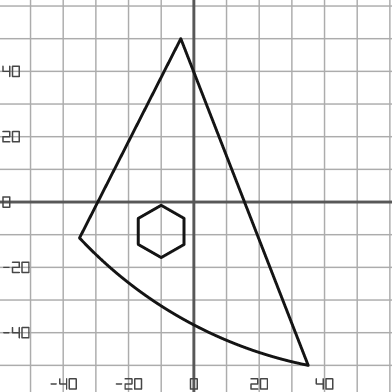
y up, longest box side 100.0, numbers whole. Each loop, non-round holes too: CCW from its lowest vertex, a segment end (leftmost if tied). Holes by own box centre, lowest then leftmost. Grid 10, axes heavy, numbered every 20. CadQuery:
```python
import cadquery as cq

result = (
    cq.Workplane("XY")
    .moveTo(35.0, -50.0)
    .lineTo(-4.0, 50.0)
    .lineTo(-35.0, -11.0)
    .threePointArc((-3.0, -36.0), (35.0, -50.0))
    .close()
    .moveTo(-10.0, -17.0)
    .lineTo(-3.0, -13.0)
    .lineTo(-3.0, -5.0)
    .lineTo(-10.0, -1.0)
    .lineTo(-17.0, -5.0)
    .lineTo(-17.0, -13.0)
    .close()
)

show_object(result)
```